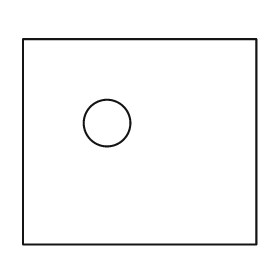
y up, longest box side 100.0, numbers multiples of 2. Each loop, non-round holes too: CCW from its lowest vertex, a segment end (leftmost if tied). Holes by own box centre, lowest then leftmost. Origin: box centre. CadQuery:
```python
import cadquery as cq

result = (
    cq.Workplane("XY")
    .moveTo(-50.0, -44.0)
    .lineTo(50.0, -44.0)
    .lineTo(50.0, 44.0)
    .lineTo(-50.0, 44.0)
    .close()
    .moveTo(-14.0, 8.0)
    .circle(10.0)
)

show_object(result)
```